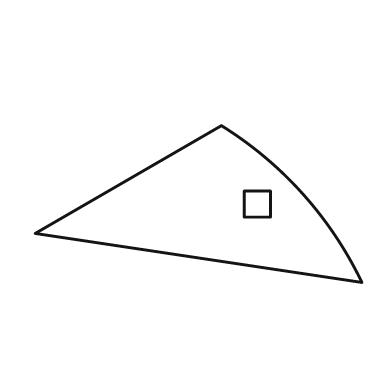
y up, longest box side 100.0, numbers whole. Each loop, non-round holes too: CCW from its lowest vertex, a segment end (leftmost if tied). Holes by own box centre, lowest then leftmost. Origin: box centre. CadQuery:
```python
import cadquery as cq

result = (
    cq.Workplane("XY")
    .moveTo(50.0, -24.0)
    .threePointArc((32.0, 3.0), (7.0, 24.0))
    .lineTo(-50.0, -9.0)
    .close()
    .moveTo(14.0, -4.0)
    .lineTo(22.0, -4.0)
    .lineTo(22.0, 4.0)
    .lineTo(14.0, 4.0)
    .close()
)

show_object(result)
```